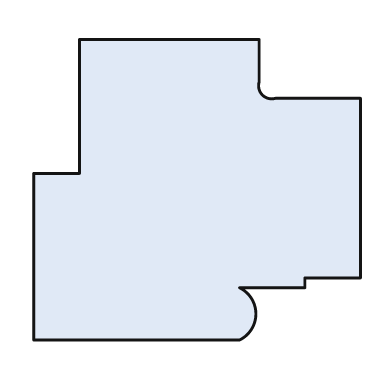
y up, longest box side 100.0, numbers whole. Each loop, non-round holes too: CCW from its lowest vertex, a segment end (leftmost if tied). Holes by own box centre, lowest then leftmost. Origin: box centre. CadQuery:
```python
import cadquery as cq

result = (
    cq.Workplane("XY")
    .moveTo(-50.0, -46.0)
    .lineTo(13.0, -46.0)
    .threePointArc((18.0, -38.0), (13.0, -30.0))
    .lineTo(33.0, -30.0)
    .lineTo(33.0, -27.0)
    .lineTo(50.0, -27.0)
    .lineTo(50.0, 28.0)
    .lineTo(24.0, 28.0)
    .threePointArc((20.0, 29.0), (19.0, 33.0))
    .lineTo(19.0, 46.0)
    .lineTo(-36.0, 46.0)
    .lineTo(-36.0, 5.0)
    .lineTo(-50.0, 5.0)
    .close()
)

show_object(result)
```